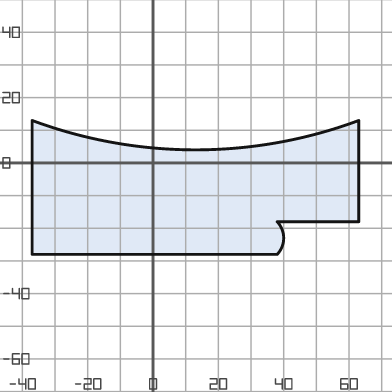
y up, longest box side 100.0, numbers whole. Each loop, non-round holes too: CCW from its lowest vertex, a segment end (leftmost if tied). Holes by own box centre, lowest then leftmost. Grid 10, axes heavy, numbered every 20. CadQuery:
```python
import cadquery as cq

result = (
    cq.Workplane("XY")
    .moveTo(-37.0, -28.0)
    .lineTo(38.0, -28.0)
    .threePointArc((40.0, -23.0), (38.0, -18.0))
    .lineTo(63.0, -18.0)
    .lineTo(63.0, 13.0)
    .threePointArc((13.0, 4.0), (-37.0, 13.0))
    .close()
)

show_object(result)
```